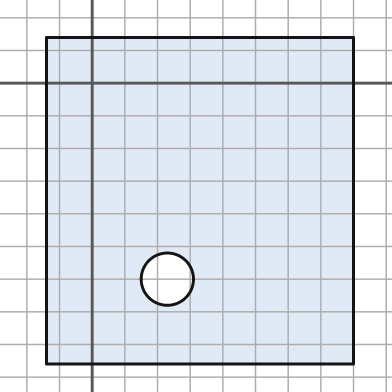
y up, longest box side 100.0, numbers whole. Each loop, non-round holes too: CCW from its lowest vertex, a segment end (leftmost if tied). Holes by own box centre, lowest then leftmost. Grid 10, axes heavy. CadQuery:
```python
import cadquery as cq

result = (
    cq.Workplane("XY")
    .moveTo(-14.0, -86.0)
    .lineTo(80.0, -86.0)
    .lineTo(80.0, 14.0)
    .lineTo(-14.0, 14.0)
    .close()
    .moveTo(23.0, -60.0)
    .circle(8.0)
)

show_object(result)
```